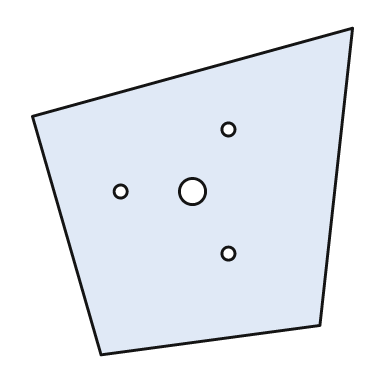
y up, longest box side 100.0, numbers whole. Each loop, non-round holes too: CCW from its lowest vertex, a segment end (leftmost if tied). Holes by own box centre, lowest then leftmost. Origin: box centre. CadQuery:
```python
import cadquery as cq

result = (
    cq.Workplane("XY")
    .moveTo(-28.0, -50.0)
    .lineTo(39.0, -41.0)
    .lineTo(49.0, 50.0)
    .lineTo(-49.0, 23.0)
    .close()
    .moveTo(11.0, -19.0)
    .circle(2.0)
    .moveTo(-22.0, 0.0)
    .circle(2.0)
    .moveTo(0.0, 0.0)
    .circle(4.0)
    .moveTo(11.0, 19.0)
    .circle(2.0)
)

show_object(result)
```